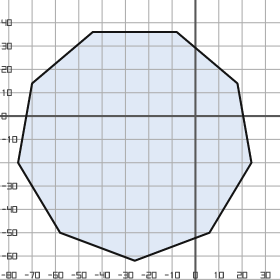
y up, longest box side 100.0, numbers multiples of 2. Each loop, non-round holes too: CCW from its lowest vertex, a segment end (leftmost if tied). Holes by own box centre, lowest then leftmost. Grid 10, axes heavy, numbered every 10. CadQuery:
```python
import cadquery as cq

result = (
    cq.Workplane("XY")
    .moveTo(-26.0, -62.0)
    .lineTo(6.0, -50.0)
    .lineTo(24.0, -20.0)
    .lineTo(18.0, 14.0)
    .lineTo(-8.0, 36.0)
    .lineTo(-44.0, 36.0)
    .lineTo(-70.0, 14.0)
    .lineTo(-76.0, -20.0)
    .lineTo(-58.0, -50.0)
    .close()
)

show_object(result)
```